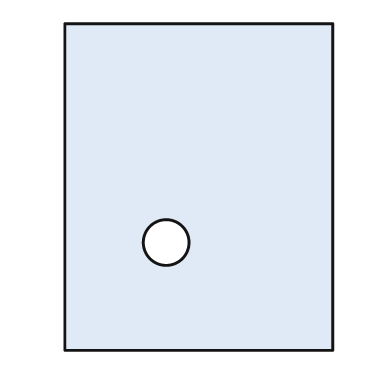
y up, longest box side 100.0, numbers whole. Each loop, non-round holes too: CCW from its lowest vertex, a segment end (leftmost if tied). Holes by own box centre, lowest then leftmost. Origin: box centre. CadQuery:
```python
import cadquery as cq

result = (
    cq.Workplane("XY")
    .moveTo(-41.0, -50.0)
    .lineTo(41.0, -50.0)
    .lineTo(41.0, 50.0)
    .lineTo(-41.0, 50.0)
    .close()
    .moveTo(-10.0, -17.0)
    .circle(7.0)
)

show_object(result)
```